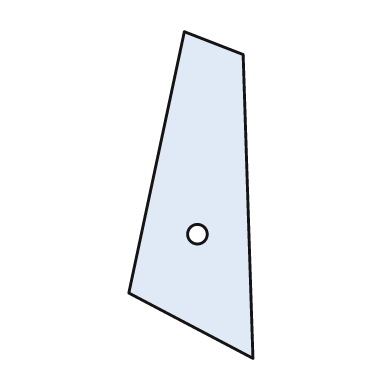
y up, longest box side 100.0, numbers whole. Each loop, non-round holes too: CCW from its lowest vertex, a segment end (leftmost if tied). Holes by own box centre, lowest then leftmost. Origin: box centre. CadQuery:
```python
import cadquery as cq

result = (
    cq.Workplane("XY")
    .moveTo(19.0, -50.0)
    .lineTo(16.0, 43.0)
    .lineTo(-2.0, 50.0)
    .lineTo(-19.0, -30.0)
    .close()
    .moveTo(2.0, -12.0)
    .circle(3.0)
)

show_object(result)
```